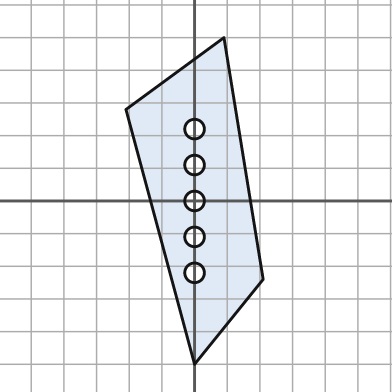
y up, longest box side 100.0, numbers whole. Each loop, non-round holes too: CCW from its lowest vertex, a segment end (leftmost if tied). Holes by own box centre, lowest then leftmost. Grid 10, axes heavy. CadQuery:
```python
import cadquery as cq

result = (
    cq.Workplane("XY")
    .moveTo(0.0, -50.0)
    .lineTo(21.0, -24.0)
    .lineTo(9.0, 50.0)
    .lineTo(-21.0, 28.0)
    .close()
    .moveTo(0.0, -22.0)
    .circle(3.0)
    .moveTo(0.0, -11.0)
    .circle(3.0)
    .moveTo(0.0, 0.0)
    .circle(3.0)
    .moveTo(0.0, 11.0)
    .circle(3.0)
    .moveTo(0.0, 22.0)
    .circle(3.0)
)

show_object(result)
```